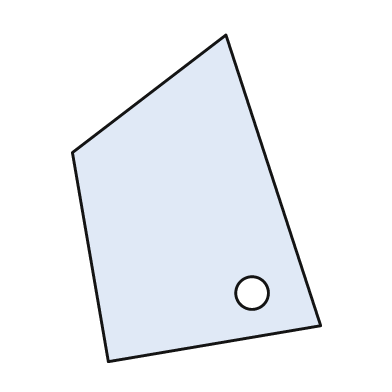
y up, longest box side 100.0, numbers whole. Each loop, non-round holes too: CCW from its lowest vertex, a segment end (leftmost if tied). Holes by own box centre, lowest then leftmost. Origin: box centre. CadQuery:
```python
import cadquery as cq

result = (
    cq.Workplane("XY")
    .moveTo(-27.0, -50.0)
    .lineTo(38.0, -39.0)
    .lineTo(9.0, 50.0)
    .lineTo(-38.0, 14.0)
    .close()
    .moveTo(17.0, -29.0)
    .circle(5.0)
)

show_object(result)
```